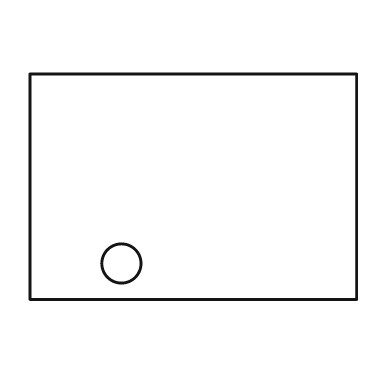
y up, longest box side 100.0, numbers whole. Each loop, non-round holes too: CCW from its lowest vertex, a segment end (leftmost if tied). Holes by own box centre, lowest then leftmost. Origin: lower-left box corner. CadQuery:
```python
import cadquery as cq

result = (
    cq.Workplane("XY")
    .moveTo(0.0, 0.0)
    .lineTo(100.0, 0.0)
    .lineTo(100.0, 69.0)
    .lineTo(0.0, 69.0)
    .close()
    .moveTo(28.0, 11.0)
    .circle(6.0)
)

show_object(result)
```